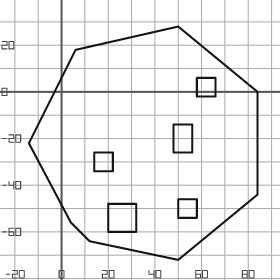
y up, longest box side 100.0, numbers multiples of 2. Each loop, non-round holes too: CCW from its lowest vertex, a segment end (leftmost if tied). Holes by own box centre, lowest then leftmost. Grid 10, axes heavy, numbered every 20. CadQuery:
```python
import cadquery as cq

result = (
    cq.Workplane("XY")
    .moveTo(50.0, -72.0)
    .lineTo(84.0, -44.0)
    .lineTo(84.0, 0.0)
    .lineTo(50.0, 28.0)
    .lineTo(6.0, 18.0)
    .lineTo(-14.0, -22.0)
    .lineTo(4.0, -56.0)
    .lineTo(12.0, -64.0)
    .close()
    .moveTo(20.0, -60.0)
    .lineTo(32.0, -60.0)
    .lineTo(32.0, -48.0)
    .lineTo(20.0, -48.0)
    .close()
    .moveTo(50.0, -54.0)
    .lineTo(58.0, -54.0)
    .lineTo(58.0, -46.0)
    .lineTo(50.0, -46.0)
    .close()
    .moveTo(14.0, -34.0)
    .lineTo(22.0, -34.0)
    .lineTo(22.0, -26.0)
    .lineTo(14.0, -26.0)
    .close()
    .moveTo(48.0, -26.0)
    .lineTo(56.0, -26.0)
    .lineTo(56.0, -14.0)
    .lineTo(48.0, -14.0)
    .close()
    .moveTo(58.0, -2.0)
    .lineTo(66.0, -2.0)
    .lineTo(66.0, 6.0)
    .lineTo(58.0, 6.0)
    .close()
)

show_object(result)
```